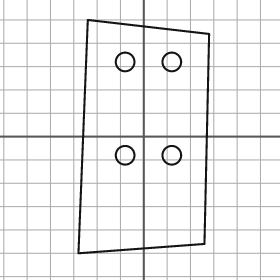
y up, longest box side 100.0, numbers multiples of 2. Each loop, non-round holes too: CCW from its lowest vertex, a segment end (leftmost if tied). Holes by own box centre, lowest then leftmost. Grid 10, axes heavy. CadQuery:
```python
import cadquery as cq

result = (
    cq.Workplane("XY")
    .moveTo(-28.0, -50.0)
    .lineTo(26.0, -46.0)
    .lineTo(28.0, 44.0)
    .lineTo(-24.0, 50.0)
    .close()
    .moveTo(-8.0, -8.0)
    .circle(4.0)
    .moveTo(12.0, -8.0)
    .circle(4.0)
    .moveTo(-8.0, 32.0)
    .circle(4.0)
    .moveTo(12.0, 32.0)
    .circle(4.0)
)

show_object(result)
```